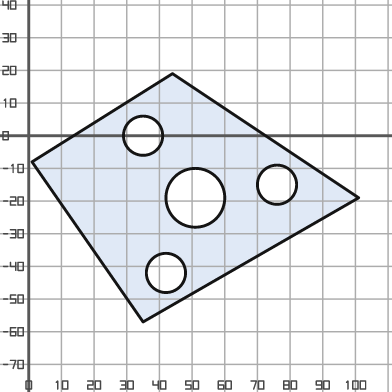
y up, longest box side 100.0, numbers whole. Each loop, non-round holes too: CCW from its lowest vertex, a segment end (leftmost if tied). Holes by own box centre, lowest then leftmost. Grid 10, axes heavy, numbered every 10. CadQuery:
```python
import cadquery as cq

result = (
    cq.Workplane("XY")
    .moveTo(35.0, -57.0)
    .lineTo(101.0, -19.0)
    .lineTo(44.0, 19.0)
    .lineTo(1.0, -8.0)
    .close()
    .moveTo(42.0, -42.0)
    .circle(6.0)
    .moveTo(51.0, -19.0)
    .circle(9.0)
    .moveTo(76.0, -15.0)
    .circle(6.0)
    .moveTo(35.0, 0.0)
    .circle(6.0)
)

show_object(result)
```